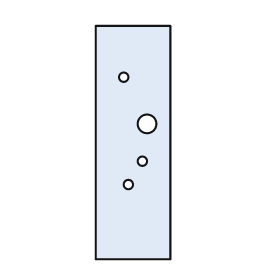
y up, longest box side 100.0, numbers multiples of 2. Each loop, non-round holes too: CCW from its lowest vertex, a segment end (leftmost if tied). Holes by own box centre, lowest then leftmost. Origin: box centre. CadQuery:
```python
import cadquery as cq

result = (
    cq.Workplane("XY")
    .moveTo(-16.0, -50.0)
    .lineTo(16.0, -50.0)
    .lineTo(16.0, 50.0)
    .lineTo(-16.0, 50.0)
    .close()
    .moveTo(-2.0, -18.0)
    .circle(2.0)
    .moveTo(4.0, -8.0)
    .circle(2.0)
    .moveTo(6.0, 8.0)
    .circle(4.0)
    .moveTo(-4.0, 28.0)
    .circle(2.0)
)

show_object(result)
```